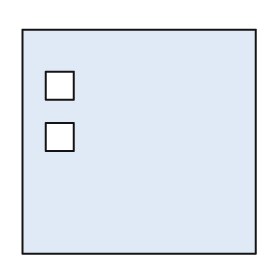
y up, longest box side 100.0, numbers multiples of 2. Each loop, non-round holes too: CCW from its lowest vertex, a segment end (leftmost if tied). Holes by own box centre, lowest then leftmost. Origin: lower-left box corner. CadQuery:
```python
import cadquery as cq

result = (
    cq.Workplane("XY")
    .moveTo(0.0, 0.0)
    .lineTo(100.0, 0.0)
    .lineTo(100.0, 96.0)
    .lineTo(0.0, 96.0)
    .close()
    .moveTo(10.0, 44.0)
    .lineTo(22.0, 44.0)
    .lineTo(22.0, 56.0)
    .lineTo(10.0, 56.0)
    .close()
    .moveTo(10.0, 66.0)
    .lineTo(22.0, 66.0)
    .lineTo(22.0, 78.0)
    .lineTo(10.0, 78.0)
    .close()
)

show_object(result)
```